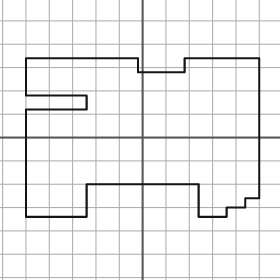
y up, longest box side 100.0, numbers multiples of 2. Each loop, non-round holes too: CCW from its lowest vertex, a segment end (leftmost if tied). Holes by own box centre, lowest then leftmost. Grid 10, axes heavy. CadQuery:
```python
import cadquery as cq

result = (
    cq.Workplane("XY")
    .moveTo(-50.0, -34.0)
    .lineTo(-24.0, -34.0)
    .lineTo(-24.0, -20.0)
    .lineTo(24.0, -20.0)
    .lineTo(24.0, -34.0)
    .lineTo(36.0, -34.0)
    .lineTo(36.0, -30.0)
    .lineTo(44.0, -30.0)
    .lineTo(44.0, -26.0)
    .lineTo(50.0, -26.0)
    .lineTo(50.0, 34.0)
    .lineTo(18.0, 34.0)
    .lineTo(18.0, 28.0)
    .lineTo(-2.0, 28.0)
    .lineTo(-2.0, 34.0)
    .lineTo(-50.0, 34.0)
    .lineTo(-50.0, 18.0)
    .lineTo(-24.0, 18.0)
    .lineTo(-24.0, 12.0)
    .lineTo(-50.0, 12.0)
    .close()
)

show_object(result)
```